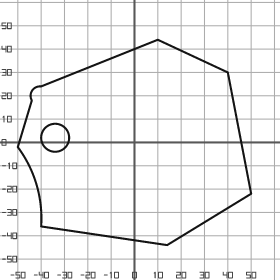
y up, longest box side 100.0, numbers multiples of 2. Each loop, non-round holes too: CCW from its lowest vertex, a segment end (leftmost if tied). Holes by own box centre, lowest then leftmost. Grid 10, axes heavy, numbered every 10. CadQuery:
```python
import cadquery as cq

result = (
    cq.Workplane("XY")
    .moveTo(14.0, -44.0)
    .lineTo(50.0, -22.0)
    .lineTo(40.0, 30.0)
    .lineTo(10.0, 44.0)
    .lineTo(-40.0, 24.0)
    .threePointArc((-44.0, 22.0), (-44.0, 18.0))
    .lineTo(-50.0, -2.0)
    .threePointArc((-42.0, -18.0), (-40.0, -36.0))
    .close()
    .moveTo(-34.0, 2.0)
    .circle(6.0)
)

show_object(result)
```